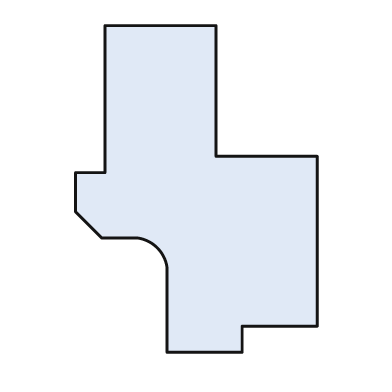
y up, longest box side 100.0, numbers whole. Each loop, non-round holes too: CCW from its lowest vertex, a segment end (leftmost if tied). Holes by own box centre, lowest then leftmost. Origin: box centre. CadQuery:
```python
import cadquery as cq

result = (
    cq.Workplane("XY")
    .moveTo(-9.0, -50.0)
    .lineTo(14.0, -50.0)
    .lineTo(14.0, -42.0)
    .lineTo(37.0, -42.0)
    .lineTo(37.0, 10.0)
    .lineTo(6.0, 10.0)
    .lineTo(6.0, 50.0)
    .lineTo(-28.0, 50.0)
    .lineTo(-28.0, 5.0)
    .lineTo(-37.0, 5.0)
    .lineTo(-37.0, -7.0)
    .lineTo(-29.0, -15.0)
    .lineTo(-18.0, -15.0)
    .threePointArc((-12.0, -18.0), (-9.0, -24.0))
    .close()
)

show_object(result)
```